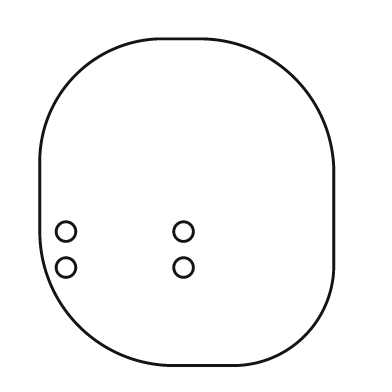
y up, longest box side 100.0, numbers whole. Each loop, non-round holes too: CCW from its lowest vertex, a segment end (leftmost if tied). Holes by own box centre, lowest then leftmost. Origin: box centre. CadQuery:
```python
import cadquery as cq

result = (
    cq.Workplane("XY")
    .moveTo(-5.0, -50.0)
    .lineTo(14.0, -50.0)
    .threePointArc((36.0, -41.0), (45.0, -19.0))
    .lineTo(45.0, 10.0)
    .threePointArc((33.0, 38.0), (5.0, 50.0))
    .lineTo(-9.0, 50.0)
    .threePointArc((-34.0, 39.0), (-45.0, 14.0))
    .lineTo(-45.0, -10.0)
    .threePointArc((-33.0, -38.0), (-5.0, -50.0))
    .close()
    .moveTo(-37.0, -20.0)
    .circle(3.0)
    .moveTo(-1.0, -20.0)
    .circle(3.0)
    .moveTo(-37.0, -9.0)
    .circle(3.0)
    .moveTo(-1.0, -9.0)
    .circle(3.0)
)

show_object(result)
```